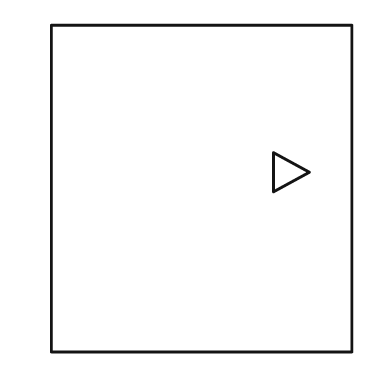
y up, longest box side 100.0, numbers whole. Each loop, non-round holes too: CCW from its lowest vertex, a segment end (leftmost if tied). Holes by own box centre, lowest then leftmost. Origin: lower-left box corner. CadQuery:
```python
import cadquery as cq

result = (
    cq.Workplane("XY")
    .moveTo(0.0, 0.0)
    .lineTo(92.0, 0.0)
    .lineTo(92.0, 100.0)
    .lineTo(0.0, 100.0)
    .close()
    .moveTo(68.0, 49.0)
    .lineTo(79.0, 55.0)
    .lineTo(68.0, 61.0)
    .close()
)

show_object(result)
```